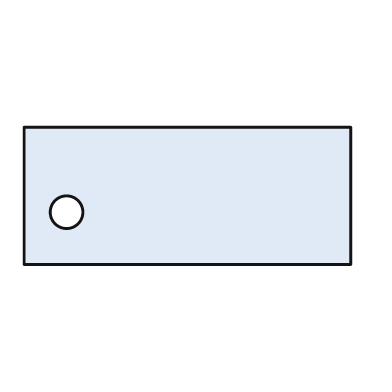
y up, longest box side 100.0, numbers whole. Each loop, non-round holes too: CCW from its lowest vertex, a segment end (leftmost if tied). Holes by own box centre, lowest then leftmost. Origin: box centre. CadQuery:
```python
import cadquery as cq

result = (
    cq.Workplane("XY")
    .moveTo(-50.0, -21.0)
    .lineTo(50.0, -21.0)
    .lineTo(50.0, 21.0)
    .lineTo(-50.0, 21.0)
    .close()
    .moveTo(-37.0, -5.0)
    .circle(5.0)
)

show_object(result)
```